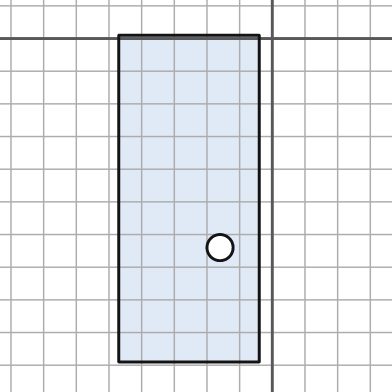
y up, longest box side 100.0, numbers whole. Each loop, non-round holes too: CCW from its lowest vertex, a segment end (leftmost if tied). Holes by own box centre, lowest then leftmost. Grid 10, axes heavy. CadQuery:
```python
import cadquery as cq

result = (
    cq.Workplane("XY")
    .moveTo(-47.0, -99.0)
    .lineTo(-4.0, -99.0)
    .lineTo(-4.0, 1.0)
    .lineTo(-47.0, 1.0)
    .close()
    .moveTo(-16.0, -64.0)
    .circle(4.0)
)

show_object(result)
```